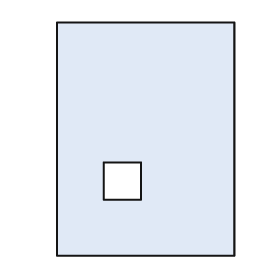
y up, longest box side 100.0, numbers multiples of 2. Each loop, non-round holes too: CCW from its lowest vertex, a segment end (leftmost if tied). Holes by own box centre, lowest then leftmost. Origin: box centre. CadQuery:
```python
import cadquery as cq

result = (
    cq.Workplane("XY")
    .moveTo(-38.0, -50.0)
    .lineTo(38.0, -50.0)
    .lineTo(38.0, 50.0)
    .lineTo(-38.0, 50.0)
    .close()
    .moveTo(-18.0, -26.0)
    .lineTo(-2.0, -26.0)
    .lineTo(-2.0, -10.0)
    .lineTo(-18.0, -10.0)
    .close()
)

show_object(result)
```